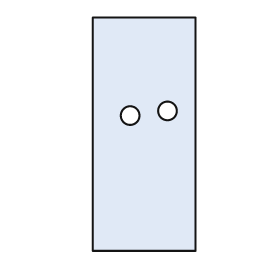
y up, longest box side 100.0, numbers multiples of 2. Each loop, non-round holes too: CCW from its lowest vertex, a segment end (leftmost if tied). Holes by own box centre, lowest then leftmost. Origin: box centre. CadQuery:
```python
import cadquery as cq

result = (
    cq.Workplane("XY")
    .moveTo(-22.0, -50.0)
    .lineTo(22.0, -50.0)
    .lineTo(22.0, 50.0)
    .lineTo(-22.0, 50.0)
    .close()
    .moveTo(-6.0, 8.0)
    .circle(4.0)
    .moveTo(10.0, 10.0)
    .circle(4.0)
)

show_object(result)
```